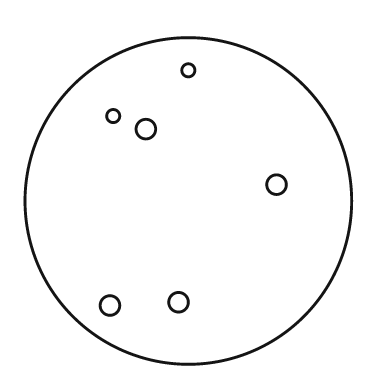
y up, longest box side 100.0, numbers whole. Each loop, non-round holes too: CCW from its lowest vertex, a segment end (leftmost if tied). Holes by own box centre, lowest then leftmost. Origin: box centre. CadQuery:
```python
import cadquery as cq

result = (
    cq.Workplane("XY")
    .moveTo(0.0, 0.0)
    .circle(50.0)
    .moveTo(-24.0, -32.0)
    .circle(3.0)
    .moveTo(-3.0, -31.0)
    .circle(3.0)
    .moveTo(27.0, 5.0)
    .circle(3.0)
    .moveTo(-13.0, 22.0)
    .circle(3.0)
    .moveTo(-23.0, 26.0)
    .circle(2.0)
    .moveTo(0.0, 40.0)
    .circle(2.0)
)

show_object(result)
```